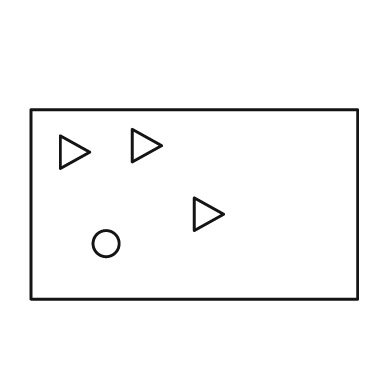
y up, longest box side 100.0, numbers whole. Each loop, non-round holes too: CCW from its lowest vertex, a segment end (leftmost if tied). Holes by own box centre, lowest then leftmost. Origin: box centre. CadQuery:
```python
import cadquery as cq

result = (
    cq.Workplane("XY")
    .moveTo(-50.0, -29.0)
    .lineTo(50.0, -29.0)
    .lineTo(50.0, 29.0)
    .lineTo(-50.0, 29.0)
    .close()
    .moveTo(-27.0, -12.0)
    .circle(4.0)
    .moveTo(0.0, -8.0)
    .lineTo(9.0, -3.0)
    .lineTo(0.0, 2.0)
    .close()
    .moveTo(-41.0, 11.0)
    .lineTo(-32.0, 16.0)
    .lineTo(-41.0, 21.0)
    .close()
    .moveTo(-19.0, 13.0)
    .lineTo(-10.0, 18.0)
    .lineTo(-19.0, 23.0)
    .close()
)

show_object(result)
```